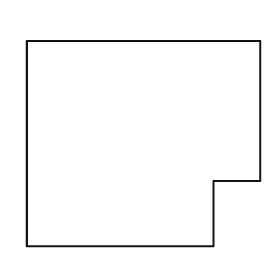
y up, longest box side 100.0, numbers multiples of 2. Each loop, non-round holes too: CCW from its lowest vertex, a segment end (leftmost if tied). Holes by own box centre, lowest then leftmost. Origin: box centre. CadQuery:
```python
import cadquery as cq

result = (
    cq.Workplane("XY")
    .moveTo(-50.0, -44.0)
    .lineTo(30.0, -44.0)
    .lineTo(30.0, -16.0)
    .lineTo(50.0, -16.0)
    .lineTo(50.0, 44.0)
    .lineTo(-50.0, 44.0)
    .close()
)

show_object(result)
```